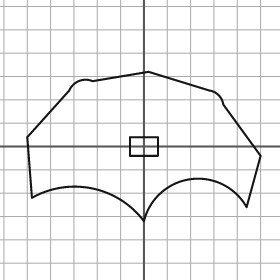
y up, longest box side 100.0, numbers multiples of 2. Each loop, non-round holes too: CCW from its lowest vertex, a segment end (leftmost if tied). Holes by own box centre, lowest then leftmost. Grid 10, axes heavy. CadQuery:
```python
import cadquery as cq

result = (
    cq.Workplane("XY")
    .moveTo(0.0, -32.0)
    .threePointArc((20.0, -14.0), (44.0, -26.0))
    .lineTo(50.0, -4.0)
    .lineTo(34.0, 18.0)
    .threePointArc((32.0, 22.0), (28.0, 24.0))
    .lineTo(2.0, 32.0)
    .lineTo(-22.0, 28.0)
    .threePointArc((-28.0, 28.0), (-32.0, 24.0))
    .lineTo(-50.0, 4.0)
    .lineTo(-48.0, -22.0)
    .threePointArc((-22.0, -18.0), (0.0, -32.0))
    .close()
    .moveTo(-6.0, -4.0)
    .lineTo(6.0, -4.0)
    .lineTo(6.0, 4.0)
    .lineTo(-6.0, 4.0)
    .close()
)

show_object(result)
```